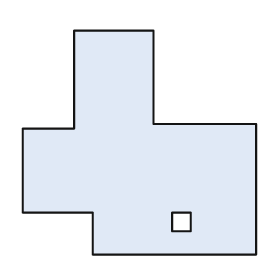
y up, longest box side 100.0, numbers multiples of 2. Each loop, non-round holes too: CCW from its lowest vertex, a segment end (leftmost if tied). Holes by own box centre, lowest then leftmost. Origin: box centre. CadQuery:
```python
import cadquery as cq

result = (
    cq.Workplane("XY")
    .moveTo(-20.0, -48.0)
    .lineTo(50.0, -48.0)
    .lineTo(50.0, 8.0)
    .lineTo(6.0, 8.0)
    .lineTo(6.0, 48.0)
    .lineTo(-28.0, 48.0)
    .lineTo(-28.0, 6.0)
    .lineTo(-50.0, 6.0)
    .lineTo(-50.0, -30.0)
    .lineTo(-20.0, -30.0)
    .close()
    .moveTo(14.0, -38.0)
    .lineTo(22.0, -38.0)
    .lineTo(22.0, -30.0)
    .lineTo(14.0, -30.0)
    .close()
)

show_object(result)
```